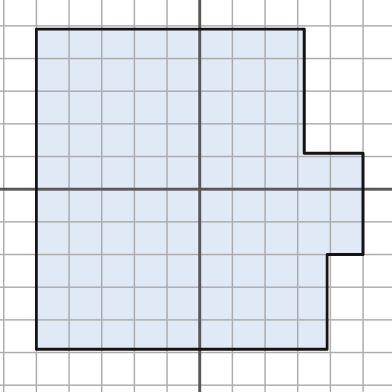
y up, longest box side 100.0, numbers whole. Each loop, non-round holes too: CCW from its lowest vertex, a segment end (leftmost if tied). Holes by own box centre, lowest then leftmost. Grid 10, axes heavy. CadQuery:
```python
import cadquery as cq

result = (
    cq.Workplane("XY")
    .moveTo(-50.0, -49.0)
    .lineTo(39.0, -49.0)
    .lineTo(39.0, -20.0)
    .lineTo(50.0, -20.0)
    .lineTo(50.0, 11.0)
    .lineTo(32.0, 11.0)
    .lineTo(32.0, 49.0)
    .lineTo(-50.0, 49.0)
    .close()
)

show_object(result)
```